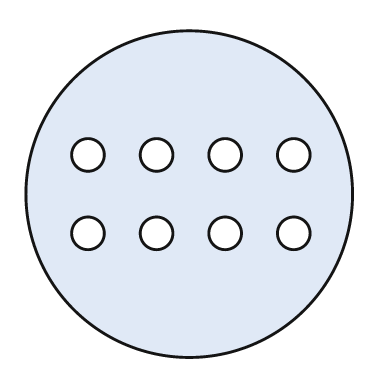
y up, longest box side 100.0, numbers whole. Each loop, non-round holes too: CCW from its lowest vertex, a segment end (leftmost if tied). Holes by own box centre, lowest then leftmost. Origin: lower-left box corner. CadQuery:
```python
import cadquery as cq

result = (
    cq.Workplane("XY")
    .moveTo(50.0, 50.0)
    .circle(50.0)
    .moveTo(19.0, 38.0)
    .circle(5.0)
    .moveTo(40.0, 38.0)
    .circle(5.0)
    .moveTo(61.0, 38.0)
    .circle(5.0)
    .moveTo(82.0, 38.0)
    .circle(5.0)
    .moveTo(19.0, 62.0)
    .circle(5.0)
    .moveTo(40.0, 62.0)
    .circle(5.0)
    .moveTo(61.0, 62.0)
    .circle(5.0)
    .moveTo(82.0, 62.0)
    .circle(5.0)
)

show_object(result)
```